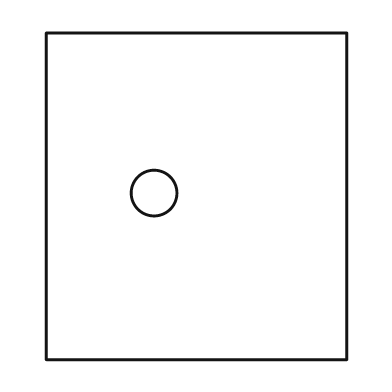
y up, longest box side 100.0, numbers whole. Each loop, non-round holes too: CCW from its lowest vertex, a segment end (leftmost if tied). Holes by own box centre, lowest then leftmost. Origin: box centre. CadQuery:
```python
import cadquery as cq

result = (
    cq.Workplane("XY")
    .moveTo(-46.0, -50.0)
    .lineTo(46.0, -50.0)
    .lineTo(46.0, 50.0)
    .lineTo(-46.0, 50.0)
    .close()
    .moveTo(-13.0, 1.0)
    .circle(7.0)
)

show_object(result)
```